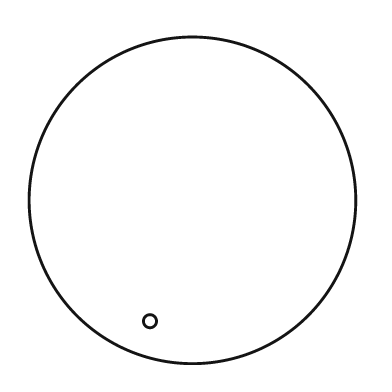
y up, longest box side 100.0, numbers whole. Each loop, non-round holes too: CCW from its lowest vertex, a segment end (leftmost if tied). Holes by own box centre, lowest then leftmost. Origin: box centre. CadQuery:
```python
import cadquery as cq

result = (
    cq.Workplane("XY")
    .moveTo(0.0, 0.0)
    .circle(50.0)
    .moveTo(-13.0, -37.0)
    .circle(2.0)
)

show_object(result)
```